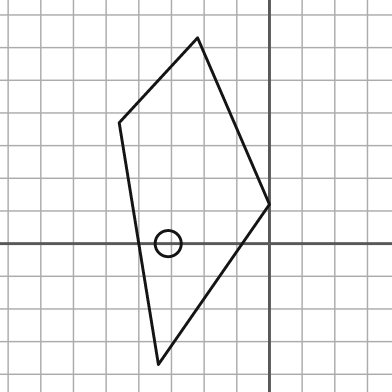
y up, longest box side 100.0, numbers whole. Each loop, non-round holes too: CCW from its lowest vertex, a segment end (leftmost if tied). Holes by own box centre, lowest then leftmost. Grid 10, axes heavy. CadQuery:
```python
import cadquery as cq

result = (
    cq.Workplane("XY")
    .moveTo(-34.0, -37.0)
    .lineTo(0.0, 12.0)
    .lineTo(-22.0, 63.0)
    .lineTo(-46.0, 37.0)
    .close()
    .moveTo(-31.0, 0.0)
    .circle(4.0)
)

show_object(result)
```